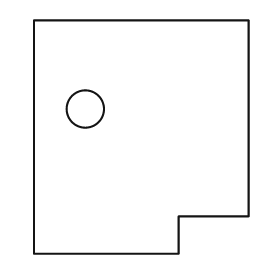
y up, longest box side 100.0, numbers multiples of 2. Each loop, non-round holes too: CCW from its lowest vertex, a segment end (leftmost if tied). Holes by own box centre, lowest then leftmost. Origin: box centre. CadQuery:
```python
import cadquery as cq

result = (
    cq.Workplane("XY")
    .moveTo(-46.0, -50.0)
    .lineTo(16.0, -50.0)
    .lineTo(16.0, -34.0)
    .lineTo(46.0, -34.0)
    .lineTo(46.0, 50.0)
    .lineTo(-46.0, 50.0)
    .close()
    .moveTo(-24.0, 12.0)
    .circle(8.0)
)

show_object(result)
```